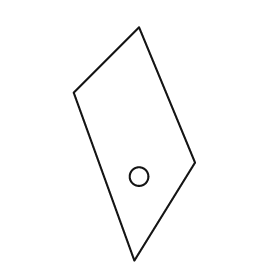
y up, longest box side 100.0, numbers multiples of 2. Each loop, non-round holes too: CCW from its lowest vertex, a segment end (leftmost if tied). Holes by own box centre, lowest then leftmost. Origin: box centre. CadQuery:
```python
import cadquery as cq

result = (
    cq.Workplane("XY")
    .moveTo(0.0, -50.0)
    .lineTo(26.0, -8.0)
    .lineTo(2.0, 50.0)
    .lineTo(-26.0, 22.0)
    .close()
    .moveTo(2.0, -14.0)
    .circle(4.0)
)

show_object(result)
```